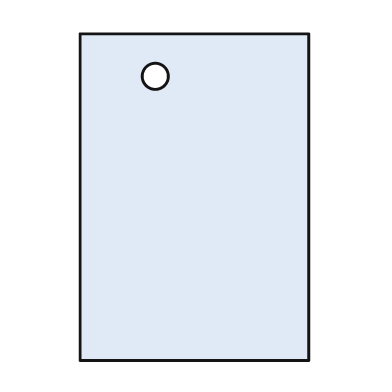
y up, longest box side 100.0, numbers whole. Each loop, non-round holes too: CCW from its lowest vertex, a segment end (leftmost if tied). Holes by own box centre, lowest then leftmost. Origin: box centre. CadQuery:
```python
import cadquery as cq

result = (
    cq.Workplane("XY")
    .moveTo(-35.0, -50.0)
    .lineTo(35.0, -50.0)
    .lineTo(35.0, 50.0)
    .lineTo(-35.0, 50.0)
    .close()
    .moveTo(-12.0, 37.0)
    .circle(4.0)
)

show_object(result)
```